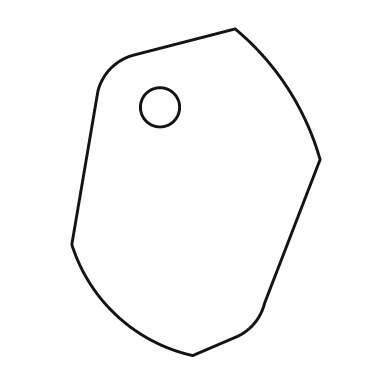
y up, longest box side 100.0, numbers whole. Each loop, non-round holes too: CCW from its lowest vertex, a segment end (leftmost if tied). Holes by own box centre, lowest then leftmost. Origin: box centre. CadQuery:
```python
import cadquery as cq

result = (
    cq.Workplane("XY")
    .moveTo(-1.0, -50.0)
    .lineTo(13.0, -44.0)
    .threePointArc((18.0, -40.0), (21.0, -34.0))
    .lineTo(38.0, 10.0)
    .threePointArc((28.0, 32.0), (12.0, 50.0))
    .lineTo(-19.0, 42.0)
    .threePointArc((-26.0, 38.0), (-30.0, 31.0))
    .lineTo(-38.0, -16.0)
    .threePointArc((-24.0, -38.0), (-1.0, -50.0))
    .close()
    .moveTo(-11.0, 26.0)
    .circle(6.0)
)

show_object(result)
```